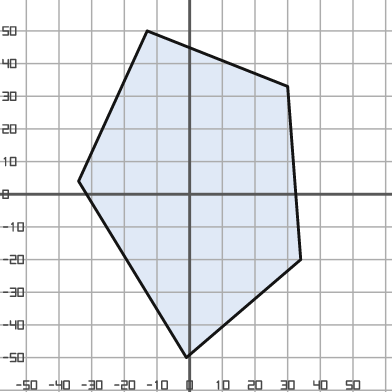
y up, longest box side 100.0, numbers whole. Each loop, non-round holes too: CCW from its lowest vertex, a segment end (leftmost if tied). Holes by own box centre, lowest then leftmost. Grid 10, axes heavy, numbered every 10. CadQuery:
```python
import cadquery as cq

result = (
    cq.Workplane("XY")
    .moveTo(-1.0, -50.0)
    .lineTo(34.0, -20.0)
    .lineTo(30.0, 33.0)
    .lineTo(-13.0, 50.0)
    .lineTo(-34.0, 4.0)
    .close()
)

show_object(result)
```